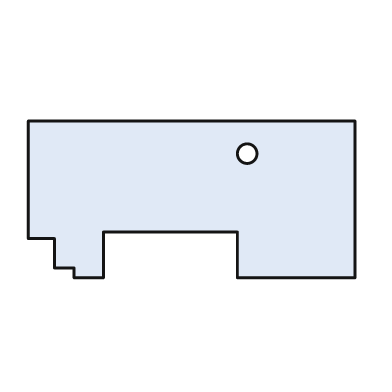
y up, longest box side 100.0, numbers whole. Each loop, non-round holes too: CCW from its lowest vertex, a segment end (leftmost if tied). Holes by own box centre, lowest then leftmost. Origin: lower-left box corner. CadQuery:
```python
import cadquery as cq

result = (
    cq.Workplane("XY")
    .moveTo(14.0, 0.0)
    .lineTo(23.0, 0.0)
    .lineTo(23.0, 14.0)
    .lineTo(64.0, 14.0)
    .lineTo(64.0, 0.0)
    .lineTo(100.0, 0.0)
    .lineTo(100.0, 48.0)
    .lineTo(0.0, 48.0)
    .lineTo(0.0, 12.0)
    .lineTo(8.0, 12.0)
    .lineTo(8.0, 3.0)
    .lineTo(14.0, 3.0)
    .close()
    .moveTo(67.0, 38.0)
    .circle(3.0)
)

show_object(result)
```